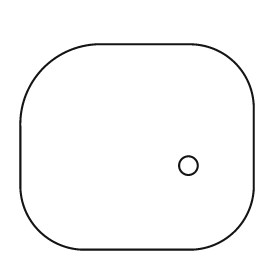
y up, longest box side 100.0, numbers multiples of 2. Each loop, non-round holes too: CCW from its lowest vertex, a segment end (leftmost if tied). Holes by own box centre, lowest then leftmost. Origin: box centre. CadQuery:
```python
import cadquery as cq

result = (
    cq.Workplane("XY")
    .moveTo(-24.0, -44.0)
    .lineTo(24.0, -44.0)
    .threePointArc((42.0, -36.0), (50.0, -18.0))
    .lineTo(50.0, 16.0)
    .threePointArc((42.0, 36.0), (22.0, 44.0))
    .lineTo(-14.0, 44.0)
    .threePointArc((-40.0, 34.0), (-50.0, 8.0))
    .lineTo(-50.0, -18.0)
    .threePointArc((-42.0, -36.0), (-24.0, -44.0))
    .close()
    .moveTo(22.0, -8.0)
    .circle(4.0)
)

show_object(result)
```